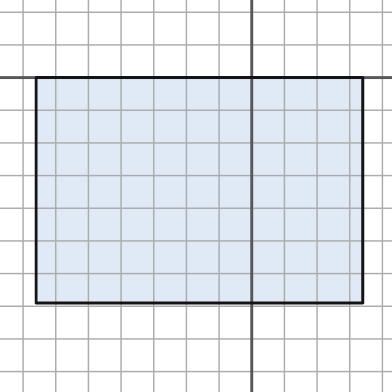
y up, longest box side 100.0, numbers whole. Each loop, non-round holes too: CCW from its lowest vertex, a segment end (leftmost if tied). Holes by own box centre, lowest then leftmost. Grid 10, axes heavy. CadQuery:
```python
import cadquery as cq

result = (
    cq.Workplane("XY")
    .moveTo(-66.0, -69.0)
    .lineTo(34.0, -69.0)
    .lineTo(34.0, 0.0)
    .lineTo(-66.0, 0.0)
    .close()
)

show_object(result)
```